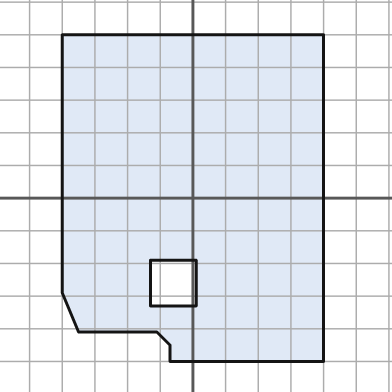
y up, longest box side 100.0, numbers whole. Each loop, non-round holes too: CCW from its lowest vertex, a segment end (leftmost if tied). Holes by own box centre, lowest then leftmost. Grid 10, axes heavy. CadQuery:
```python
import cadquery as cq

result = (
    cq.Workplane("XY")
    .moveTo(-7.0, -50.0)
    .lineTo(40.0, -50.0)
    .lineTo(40.0, 50.0)
    .lineTo(-40.0, 50.0)
    .lineTo(-40.0, -29.0)
    .lineTo(-35.0, -41.0)
    .lineTo(-11.0, -41.0)
    .lineTo(-7.0, -45.0)
    .close()
    .moveTo(-13.0, -33.0)
    .lineTo(1.0, -33.0)
    .lineTo(1.0, -19.0)
    .lineTo(-13.0, -19.0)
    .close()
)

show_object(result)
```